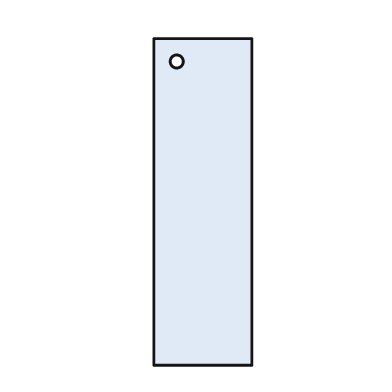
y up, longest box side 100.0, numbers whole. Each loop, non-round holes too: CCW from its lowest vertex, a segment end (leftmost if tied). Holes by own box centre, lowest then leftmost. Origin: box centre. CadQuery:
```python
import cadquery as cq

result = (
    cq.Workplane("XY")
    .moveTo(-15.0, -50.0)
    .lineTo(15.0, -50.0)
    .lineTo(15.0, 50.0)
    .lineTo(-15.0, 50.0)
    .close()
    .moveTo(-8.0, 43.0)
    .circle(2.0)
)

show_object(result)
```